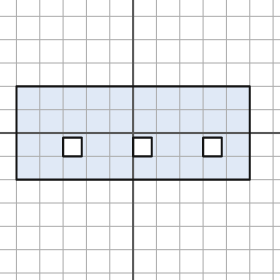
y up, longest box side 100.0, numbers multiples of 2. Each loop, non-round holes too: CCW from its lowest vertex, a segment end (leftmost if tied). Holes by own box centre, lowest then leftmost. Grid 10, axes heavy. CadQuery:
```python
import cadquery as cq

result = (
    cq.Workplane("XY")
    .moveTo(-50.0, -20.0)
    .lineTo(50.0, -20.0)
    .lineTo(50.0, 20.0)
    .lineTo(-50.0, 20.0)
    .close()
    .moveTo(-30.0, -10.0)
    .lineTo(-22.0, -10.0)
    .lineTo(-22.0, -2.0)
    .lineTo(-30.0, -2.0)
    .close()
    .moveTo(0.0, -10.0)
    .lineTo(8.0, -10.0)
    .lineTo(8.0, -2.0)
    .lineTo(0.0, -2.0)
    .close()
    .moveTo(30.0, -10.0)
    .lineTo(38.0, -10.0)
    .lineTo(38.0, -2.0)
    .lineTo(30.0, -2.0)
    .close()
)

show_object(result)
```